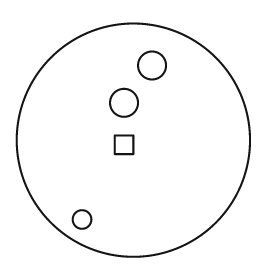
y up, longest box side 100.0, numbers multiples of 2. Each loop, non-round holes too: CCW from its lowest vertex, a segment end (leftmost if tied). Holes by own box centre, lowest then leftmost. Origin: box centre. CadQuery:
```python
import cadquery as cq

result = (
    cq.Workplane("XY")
    .moveTo(0.0, 0.0)
    .circle(50.0)
    .moveTo(-22.0, -34.0)
    .circle(4.0)
    .moveTo(-8.0, -6.0)
    .lineTo(0.0, -6.0)
    .lineTo(0.0, 2.0)
    .lineTo(-8.0, 2.0)
    .close()
    .moveTo(-4.0, 16.0)
    .circle(6.0)
    .moveTo(8.0, 32.0)
    .circle(6.0)
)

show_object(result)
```